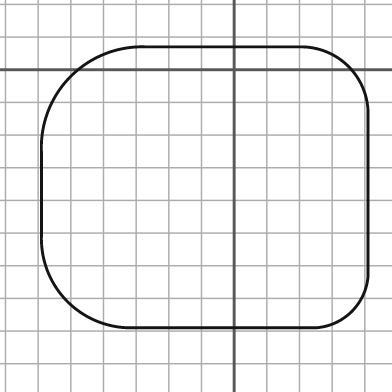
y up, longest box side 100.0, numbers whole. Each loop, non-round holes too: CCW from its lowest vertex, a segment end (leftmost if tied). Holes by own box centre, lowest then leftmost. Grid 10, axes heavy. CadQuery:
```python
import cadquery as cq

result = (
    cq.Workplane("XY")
    .moveTo(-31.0, -79.0)
    .lineTo(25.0, -79.0)
    .threePointArc((36.0, -74.0), (41.0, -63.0))
    .lineTo(41.0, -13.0)
    .threePointArc((35.0, 1.0), (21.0, 7.0))
    .lineTo(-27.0, 7.0)
    .threePointArc((-50.0, -2.0), (-59.0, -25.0))
    .lineTo(-59.0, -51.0)
    .threePointArc((-51.0, -71.0), (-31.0, -79.0))
    .close()
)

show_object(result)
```